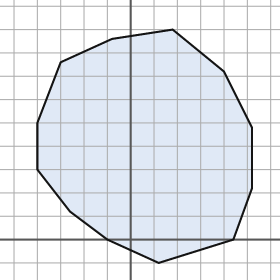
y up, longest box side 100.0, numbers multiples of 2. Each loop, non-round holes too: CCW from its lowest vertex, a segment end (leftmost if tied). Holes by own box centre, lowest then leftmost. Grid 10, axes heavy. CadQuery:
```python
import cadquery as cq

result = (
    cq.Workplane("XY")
    .moveTo(12.0, -10.0)
    .lineTo(44.0, 0.0)
    .lineTo(52.0, 22.0)
    .lineTo(52.0, 48.0)
    .lineTo(40.0, 72.0)
    .lineTo(18.0, 90.0)
    .lineTo(-8.0, 86.0)
    .lineTo(-30.0, 76.0)
    .lineTo(-40.0, 50.0)
    .lineTo(-40.0, 30.0)
    .lineTo(-26.0, 12.0)
    .lineTo(-10.0, 0.0)
    .close()
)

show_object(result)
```